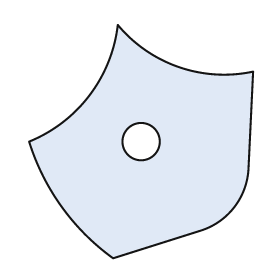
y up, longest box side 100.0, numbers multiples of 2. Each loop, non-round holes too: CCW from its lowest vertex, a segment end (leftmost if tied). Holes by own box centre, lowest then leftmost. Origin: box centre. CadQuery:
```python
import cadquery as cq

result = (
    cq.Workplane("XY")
    .moveTo(-12.0, -50.0)
    .lineTo(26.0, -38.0)
    .threePointArc((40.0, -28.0), (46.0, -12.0))
    .lineTo(48.0, 30.0)
    .threePointArc((16.0, 32.0), (-10.0, 50.0))
    .threePointArc((-22.0, 20.0), (-48.0, 0.0))
    .threePointArc((-34.0, -28.0), (-12.0, -50.0))
    .close()
    .moveTo(0.0, 0.0)
    .circle(8.0)
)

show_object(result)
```